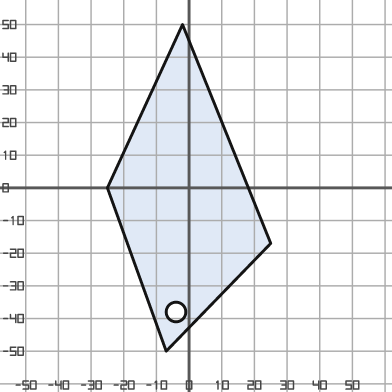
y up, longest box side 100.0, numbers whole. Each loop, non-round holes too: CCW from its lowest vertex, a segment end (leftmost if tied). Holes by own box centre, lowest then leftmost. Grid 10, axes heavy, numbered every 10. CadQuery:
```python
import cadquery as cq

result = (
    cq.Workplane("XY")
    .moveTo(-7.0, -50.0)
    .lineTo(25.0, -17.0)
    .lineTo(-2.0, 50.0)
    .lineTo(-25.0, 0.0)
    .close()
    .moveTo(-4.0, -38.0)
    .circle(3.0)
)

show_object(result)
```